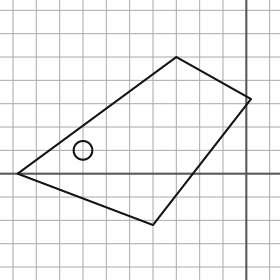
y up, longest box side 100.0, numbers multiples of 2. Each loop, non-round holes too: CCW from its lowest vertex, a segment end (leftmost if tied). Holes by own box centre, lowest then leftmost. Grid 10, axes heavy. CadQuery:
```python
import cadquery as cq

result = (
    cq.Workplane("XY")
    .moveTo(-40.0, -22.0)
    .lineTo(2.0, 32.0)
    .lineTo(-30.0, 50.0)
    .lineTo(-98.0, 0.0)
    .close()
    .moveTo(-70.0, 10.0)
    .circle(4.0)
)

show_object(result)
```